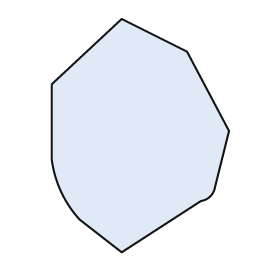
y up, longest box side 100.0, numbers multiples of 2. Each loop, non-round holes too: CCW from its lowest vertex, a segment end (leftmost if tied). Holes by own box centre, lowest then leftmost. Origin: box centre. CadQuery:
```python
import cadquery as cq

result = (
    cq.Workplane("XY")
    .moveTo(-8.0, -50.0)
    .lineTo(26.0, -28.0)
    .threePointArc((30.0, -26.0), (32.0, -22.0))
    .lineTo(38.0, 2.0)
    .lineTo(20.0, 36.0)
    .lineTo(-8.0, 50.0)
    .lineTo(-38.0, 22.0)
    .lineTo(-38.0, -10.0)
    .threePointArc((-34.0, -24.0), (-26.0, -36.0))
    .close()
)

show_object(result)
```